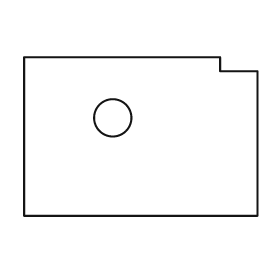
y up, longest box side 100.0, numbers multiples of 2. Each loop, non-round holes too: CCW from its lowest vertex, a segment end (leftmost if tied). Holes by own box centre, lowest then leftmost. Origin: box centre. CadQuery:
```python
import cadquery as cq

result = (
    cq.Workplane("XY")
    .moveTo(-50.0, -34.0)
    .lineTo(50.0, -34.0)
    .lineTo(50.0, 28.0)
    .lineTo(34.0, 28.0)
    .lineTo(34.0, 34.0)
    .lineTo(-50.0, 34.0)
    .close()
    .moveTo(-12.0, 8.0)
    .circle(8.0)
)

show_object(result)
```